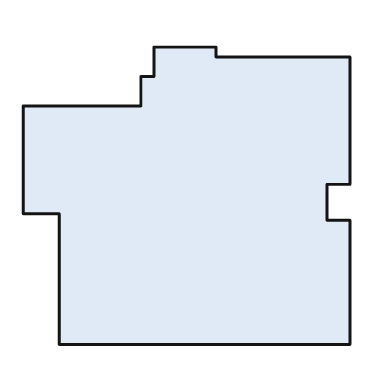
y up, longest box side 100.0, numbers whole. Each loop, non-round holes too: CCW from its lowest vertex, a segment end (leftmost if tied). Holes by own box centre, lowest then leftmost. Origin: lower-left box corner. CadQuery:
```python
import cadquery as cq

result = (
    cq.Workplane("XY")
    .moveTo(11.0, 0.0)
    .lineTo(100.0, 0.0)
    .lineTo(100.0, 38.0)
    .lineTo(93.0, 38.0)
    .lineTo(93.0, 49.0)
    .lineTo(100.0, 49.0)
    .lineTo(100.0, 88.0)
    .lineTo(59.0, 88.0)
    .lineTo(59.0, 91.0)
    .lineTo(40.0, 91.0)
    .lineTo(40.0, 82.0)
    .lineTo(36.0, 82.0)
    .lineTo(36.0, 73.0)
    .lineTo(0.0, 73.0)
    .lineTo(0.0, 40.0)
    .lineTo(11.0, 40.0)
    .close()
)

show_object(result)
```